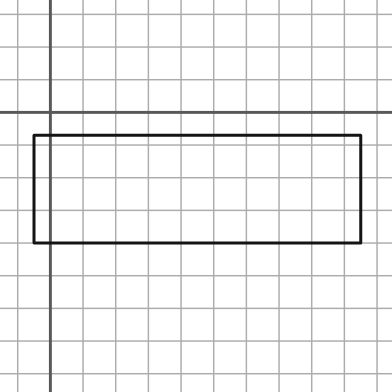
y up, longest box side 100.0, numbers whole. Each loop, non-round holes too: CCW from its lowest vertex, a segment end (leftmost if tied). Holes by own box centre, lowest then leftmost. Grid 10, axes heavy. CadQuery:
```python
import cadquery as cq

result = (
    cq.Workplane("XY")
    .moveTo(-5.0, -40.0)
    .lineTo(95.0, -40.0)
    .lineTo(95.0, -7.0)
    .lineTo(-5.0, -7.0)
    .close()
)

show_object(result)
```